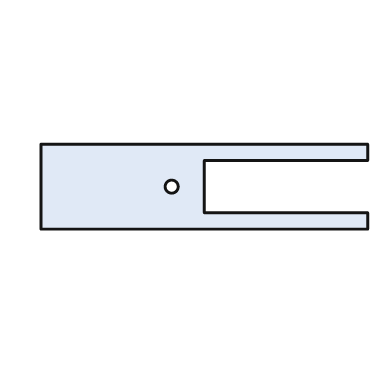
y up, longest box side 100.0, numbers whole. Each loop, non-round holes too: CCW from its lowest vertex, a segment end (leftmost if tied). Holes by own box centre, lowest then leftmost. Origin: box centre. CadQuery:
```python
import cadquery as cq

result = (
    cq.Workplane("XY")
    .moveTo(-50.0, -13.0)
    .lineTo(50.0, -13.0)
    .lineTo(50.0, -8.0)
    .lineTo(0.0, -8.0)
    .lineTo(0.0, 8.0)
    .lineTo(50.0, 8.0)
    .lineTo(50.0, 13.0)
    .lineTo(-50.0, 13.0)
    .close()
    .moveTo(-10.0, 0.0)
    .circle(2.0)
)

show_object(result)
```